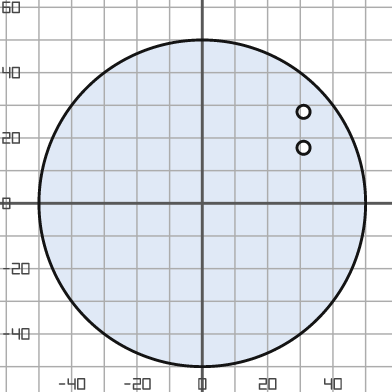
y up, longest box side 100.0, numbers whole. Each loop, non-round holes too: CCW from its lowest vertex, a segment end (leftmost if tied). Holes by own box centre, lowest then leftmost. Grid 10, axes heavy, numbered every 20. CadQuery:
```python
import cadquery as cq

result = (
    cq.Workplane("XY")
    .moveTo(0.0, 0.0)
    .circle(50.0)
    .moveTo(31.0, 17.0)
    .circle(2.0)
    .moveTo(31.0, 28.0)
    .circle(2.0)
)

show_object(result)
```